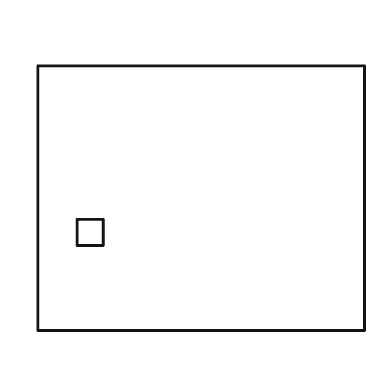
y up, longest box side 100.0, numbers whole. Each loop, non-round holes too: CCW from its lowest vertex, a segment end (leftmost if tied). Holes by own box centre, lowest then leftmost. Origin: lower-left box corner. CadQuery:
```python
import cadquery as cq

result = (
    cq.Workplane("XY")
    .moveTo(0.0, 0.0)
    .lineTo(100.0, 0.0)
    .lineTo(100.0, 81.0)
    .lineTo(0.0, 81.0)
    .close()
    .moveTo(12.0, 26.0)
    .lineTo(20.0, 26.0)
    .lineTo(20.0, 34.0)
    .lineTo(12.0, 34.0)
    .close()
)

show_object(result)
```